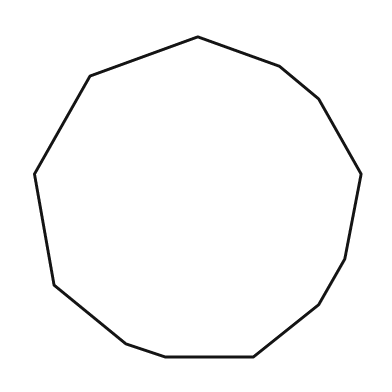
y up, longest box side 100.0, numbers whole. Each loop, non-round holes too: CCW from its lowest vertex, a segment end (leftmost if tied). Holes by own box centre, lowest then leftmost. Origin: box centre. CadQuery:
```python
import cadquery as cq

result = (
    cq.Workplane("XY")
    .moveTo(-10.0, -49.0)
    .lineTo(17.0, -49.0)
    .lineTo(37.0, -33.0)
    .lineTo(45.0, -19.0)
    .lineTo(50.0, 7.0)
    .lineTo(37.0, 30.0)
    .lineTo(25.0, 40.0)
    .lineTo(0.0, 49.0)
    .lineTo(-33.0, 37.0)
    .lineTo(-50.0, 7.0)
    .lineTo(-44.0, -27.0)
    .lineTo(-22.0, -45.0)
    .close()
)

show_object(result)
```